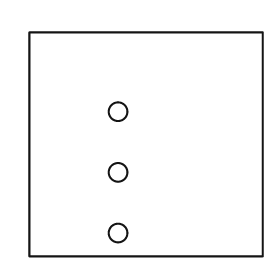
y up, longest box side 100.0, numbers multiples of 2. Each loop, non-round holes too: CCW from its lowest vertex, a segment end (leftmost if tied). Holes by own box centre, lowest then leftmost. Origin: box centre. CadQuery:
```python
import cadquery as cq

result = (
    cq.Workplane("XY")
    .moveTo(-50.0, -48.0)
    .lineTo(50.0, -48.0)
    .lineTo(50.0, 48.0)
    .lineTo(-50.0, 48.0)
    .close()
    .moveTo(-12.0, -38.0)
    .circle(4.0)
    .moveTo(-12.0, -12.0)
    .circle(4.0)
    .moveTo(-12.0, 14.0)
    .circle(4.0)
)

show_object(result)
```